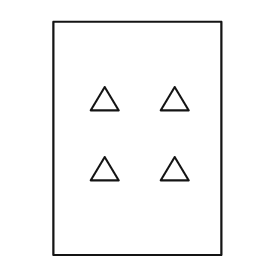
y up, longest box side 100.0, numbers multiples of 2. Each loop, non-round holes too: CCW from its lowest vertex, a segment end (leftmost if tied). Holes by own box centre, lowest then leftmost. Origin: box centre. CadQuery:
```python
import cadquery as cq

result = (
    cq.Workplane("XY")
    .moveTo(-36.0, -50.0)
    .lineTo(36.0, -50.0)
    .lineTo(36.0, 50.0)
    .lineTo(-36.0, 50.0)
    .close()
    .moveTo(-20.0, -18.0)
    .lineTo(-8.0, -18.0)
    .lineTo(-14.0, -8.0)
    .close()
    .moveTo(10.0, -18.0)
    .lineTo(22.0, -18.0)
    .lineTo(16.0, -8.0)
    .close()
    .moveTo(-20.0, 12.0)
    .lineTo(-8.0, 12.0)
    .lineTo(-14.0, 22.0)
    .close()
    .moveTo(10.0, 12.0)
    .lineTo(22.0, 12.0)
    .lineTo(16.0, 22.0)
    .close()
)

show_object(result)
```